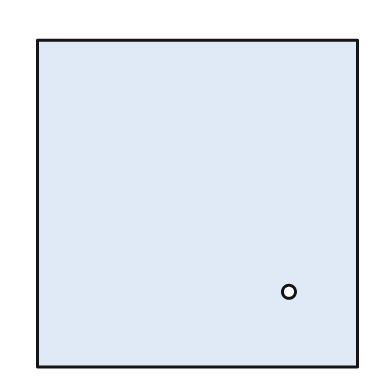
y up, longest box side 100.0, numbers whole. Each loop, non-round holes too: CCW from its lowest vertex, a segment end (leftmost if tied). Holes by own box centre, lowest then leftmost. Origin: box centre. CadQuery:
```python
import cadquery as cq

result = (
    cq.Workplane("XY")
    .moveTo(-49.0, -50.0)
    .lineTo(49.0, -50.0)
    .lineTo(49.0, 50.0)
    .lineTo(-49.0, 50.0)
    .close()
    .moveTo(28.0, -27.0)
    .circle(2.0)
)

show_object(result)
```